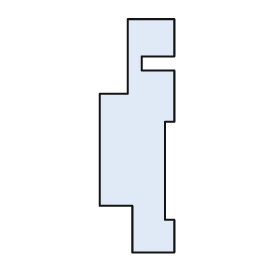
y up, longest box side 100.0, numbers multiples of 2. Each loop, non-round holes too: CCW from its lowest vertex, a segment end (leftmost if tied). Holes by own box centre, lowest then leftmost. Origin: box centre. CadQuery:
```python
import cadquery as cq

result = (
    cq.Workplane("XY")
    .moveTo(-2.0, -50.0)
    .lineTo(16.0, -50.0)
    .lineTo(16.0, -36.0)
    .lineTo(12.0, -36.0)
    .lineTo(12.0, 6.0)
    .lineTo(16.0, 6.0)
    .lineTo(16.0, 28.0)
    .lineTo(2.0, 28.0)
    .lineTo(2.0, 34.0)
    .lineTo(16.0, 34.0)
    .lineTo(16.0, 50.0)
    .lineTo(-4.0, 50.0)
    .lineTo(-4.0, 18.0)
    .lineTo(-16.0, 18.0)
    .lineTo(-16.0, -30.0)
    .lineTo(-2.0, -30.0)
    .close()
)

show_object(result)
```